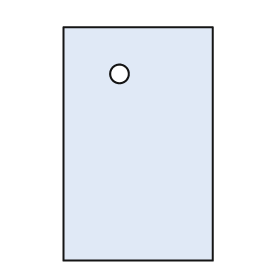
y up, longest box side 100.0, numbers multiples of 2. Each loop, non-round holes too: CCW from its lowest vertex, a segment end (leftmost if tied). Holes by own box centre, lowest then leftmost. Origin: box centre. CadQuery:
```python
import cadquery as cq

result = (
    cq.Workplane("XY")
    .moveTo(-32.0, -50.0)
    .lineTo(32.0, -50.0)
    .lineTo(32.0, 50.0)
    .lineTo(-32.0, 50.0)
    .close()
    .moveTo(-8.0, 30.0)
    .circle(4.0)
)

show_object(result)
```